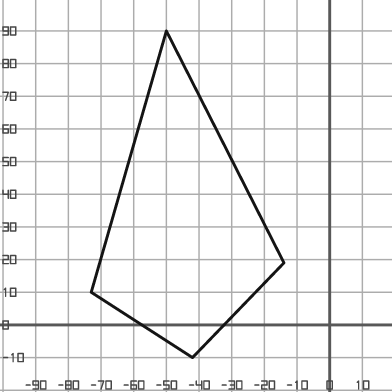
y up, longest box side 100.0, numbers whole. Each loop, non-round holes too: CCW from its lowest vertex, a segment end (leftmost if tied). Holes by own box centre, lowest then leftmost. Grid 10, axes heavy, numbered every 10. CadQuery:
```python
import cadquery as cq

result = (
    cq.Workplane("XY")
    .moveTo(-42.0, -10.0)
    .lineTo(-14.0, 19.0)
    .lineTo(-50.0, 90.0)
    .lineTo(-73.0, 10.0)
    .close()
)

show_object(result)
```